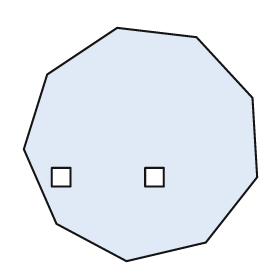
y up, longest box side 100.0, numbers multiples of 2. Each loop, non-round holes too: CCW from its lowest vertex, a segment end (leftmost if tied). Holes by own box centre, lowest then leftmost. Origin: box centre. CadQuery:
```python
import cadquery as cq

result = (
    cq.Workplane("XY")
    .moveTo(-6.0, -50.0)
    .lineTo(28.0, -42.0)
    .lineTo(50.0, -14.0)
    .lineTo(48.0, 20.0)
    .lineTo(24.0, 46.0)
    .lineTo(-10.0, 50.0)
    .lineTo(-40.0, 30.0)
    .lineTo(-50.0, -2.0)
    .lineTo(-36.0, -34.0)
    .close()
    .moveTo(-38.0, -18.0)
    .lineTo(-30.0, -18.0)
    .lineTo(-30.0, -10.0)
    .lineTo(-38.0, -10.0)
    .close()
    .moveTo(2.0, -18.0)
    .lineTo(10.0, -18.0)
    .lineTo(10.0, -10.0)
    .lineTo(2.0, -10.0)
    .close()
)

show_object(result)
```